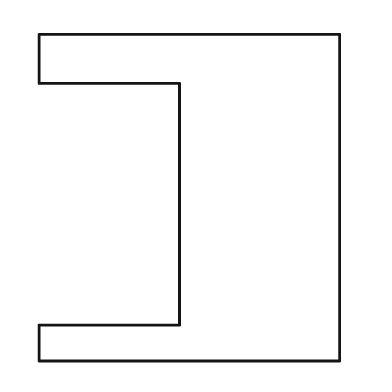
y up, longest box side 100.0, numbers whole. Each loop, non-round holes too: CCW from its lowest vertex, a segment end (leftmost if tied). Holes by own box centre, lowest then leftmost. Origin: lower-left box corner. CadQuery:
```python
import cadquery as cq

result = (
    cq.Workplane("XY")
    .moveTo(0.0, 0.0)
    .lineTo(92.0, 0.0)
    .lineTo(92.0, 100.0)
    .lineTo(0.0, 100.0)
    .lineTo(0.0, 85.0)
    .lineTo(43.0, 85.0)
    .lineTo(43.0, 11.0)
    .lineTo(0.0, 11.0)
    .close()
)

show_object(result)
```